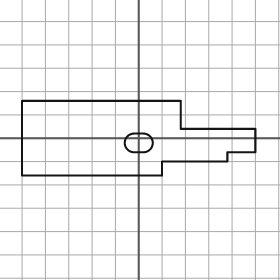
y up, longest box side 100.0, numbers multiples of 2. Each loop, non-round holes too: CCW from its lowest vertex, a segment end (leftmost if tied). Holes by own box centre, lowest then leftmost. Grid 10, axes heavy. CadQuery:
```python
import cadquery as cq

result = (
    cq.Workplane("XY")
    .moveTo(-50.0, -16.0)
    .lineTo(10.0, -16.0)
    .lineTo(10.0, -10.0)
    .lineTo(38.0, -10.0)
    .lineTo(38.0, -6.0)
    .lineTo(50.0, -6.0)
    .lineTo(50.0, 4.0)
    .lineTo(18.0, 4.0)
    .lineTo(18.0, 16.0)
    .lineTo(-50.0, 16.0)
    .close()
    .moveTo(-2.0, -6.0)
    .lineTo(2.0, -6.0)
    .threePointArc((6.0, -2.0), (2.0, 2.0))
    .lineTo(-2.0, 2.0)
    .threePointArc((-6.0, -2.0), (-2.0, -6.0))
    .close()
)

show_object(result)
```